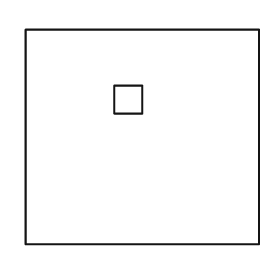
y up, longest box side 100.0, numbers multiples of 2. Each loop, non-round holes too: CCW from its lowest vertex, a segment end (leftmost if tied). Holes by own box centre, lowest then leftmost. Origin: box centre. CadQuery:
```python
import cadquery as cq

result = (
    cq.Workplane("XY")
    .moveTo(-50.0, -46.0)
    .lineTo(50.0, -46.0)
    .lineTo(50.0, 46.0)
    .lineTo(-50.0, 46.0)
    .close()
    .moveTo(-12.0, 10.0)
    .lineTo(0.0, 10.0)
    .lineTo(0.0, 22.0)
    .lineTo(-12.0, 22.0)
    .close()
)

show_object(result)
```